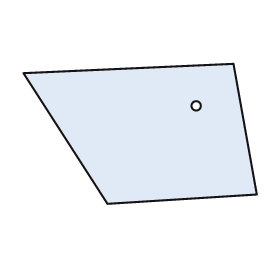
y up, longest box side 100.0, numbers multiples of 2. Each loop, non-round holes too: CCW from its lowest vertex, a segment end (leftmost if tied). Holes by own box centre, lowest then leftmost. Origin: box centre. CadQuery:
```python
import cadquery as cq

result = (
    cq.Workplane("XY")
    .moveTo(-14.0, -30.0)
    .lineTo(50.0, -26.0)
    .lineTo(40.0, 30.0)
    .lineTo(-50.0, 26.0)
    .close()
    .moveTo(24.0, 12.0)
    .circle(2.0)
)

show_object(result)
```